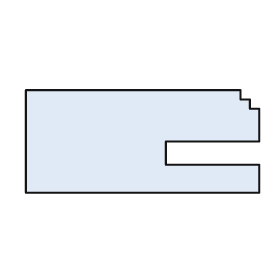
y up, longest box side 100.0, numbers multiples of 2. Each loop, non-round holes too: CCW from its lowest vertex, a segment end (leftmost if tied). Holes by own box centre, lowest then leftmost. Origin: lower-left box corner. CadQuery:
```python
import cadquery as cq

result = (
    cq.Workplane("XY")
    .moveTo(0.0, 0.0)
    .lineTo(100.0, 0.0)
    .lineTo(100.0, 12.0)
    .lineTo(60.0, 12.0)
    .lineTo(60.0, 22.0)
    .lineTo(100.0, 22.0)
    .lineTo(100.0, 36.0)
    .lineTo(96.0, 36.0)
    .lineTo(96.0, 40.0)
    .lineTo(92.0, 40.0)
    .lineTo(92.0, 44.0)
    .lineTo(0.0, 44.0)
    .close()
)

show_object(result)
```